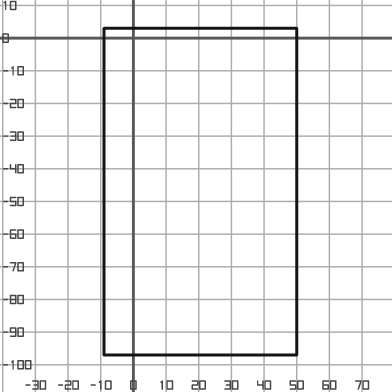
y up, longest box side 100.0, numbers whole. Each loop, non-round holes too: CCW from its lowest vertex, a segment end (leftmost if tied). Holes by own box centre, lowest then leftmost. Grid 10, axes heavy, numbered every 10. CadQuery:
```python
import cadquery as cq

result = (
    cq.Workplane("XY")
    .moveTo(-9.0, -97.0)
    .lineTo(50.0, -97.0)
    .lineTo(50.0, 3.0)
    .lineTo(-9.0, 3.0)
    .close()
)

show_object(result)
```